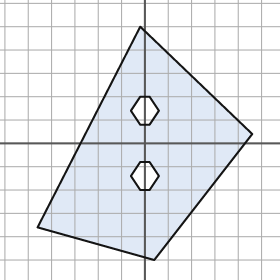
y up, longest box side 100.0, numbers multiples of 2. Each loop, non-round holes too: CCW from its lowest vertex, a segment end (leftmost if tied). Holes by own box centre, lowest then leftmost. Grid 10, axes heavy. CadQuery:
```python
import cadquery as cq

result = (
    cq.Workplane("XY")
    .moveTo(4.0, -50.0)
    .lineTo(46.0, 4.0)
    .lineTo(-2.0, 50.0)
    .lineTo(-46.0, -36.0)
    .close()
    .moveTo(-2.0, -20.0)
    .lineTo(2.0, -20.0)
    .lineTo(6.0, -14.0)
    .lineTo(2.0, -8.0)
    .lineTo(-2.0, -8.0)
    .lineTo(-6.0, -14.0)
    .close()
    .moveTo(-2.0, 8.0)
    .lineTo(2.0, 8.0)
    .lineTo(6.0, 14.0)
    .lineTo(2.0, 20.0)
    .lineTo(-2.0, 20.0)
    .lineTo(-6.0, 14.0)
    .close()
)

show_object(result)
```